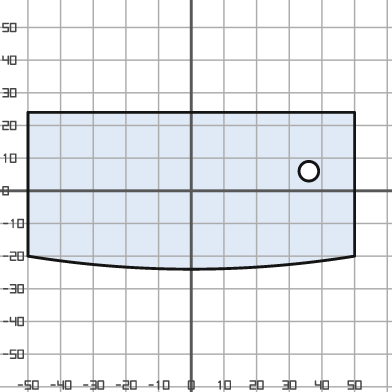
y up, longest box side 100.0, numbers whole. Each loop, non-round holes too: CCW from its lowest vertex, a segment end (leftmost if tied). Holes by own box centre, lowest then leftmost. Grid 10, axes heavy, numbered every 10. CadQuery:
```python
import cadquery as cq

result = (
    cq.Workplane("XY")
    .moveTo(-50.0, -20.0)
    .threePointArc((0.0, -24.0), (50.0, -20.0))
    .lineTo(50.0, 24.0)
    .lineTo(-50.0, 24.0)
    .close()
    .moveTo(36.0, 6.0)
    .circle(3.0)
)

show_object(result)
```